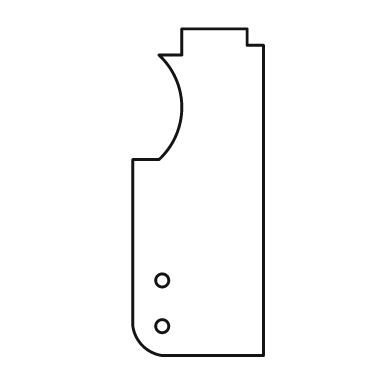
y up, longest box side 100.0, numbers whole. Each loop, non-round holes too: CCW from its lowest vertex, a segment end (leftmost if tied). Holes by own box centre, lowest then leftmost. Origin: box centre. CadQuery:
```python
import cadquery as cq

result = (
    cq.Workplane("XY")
    .moveTo(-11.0, -50.0)
    .lineTo(20.0, -50.0)
    .lineTo(20.0, 45.0)
    .lineTo(15.0, 45.0)
    .lineTo(15.0, 50.0)
    .lineTo(-5.0, 50.0)
    .lineTo(-5.0, 42.0)
    .lineTo(-12.0, 42.0)
    .threePointArc((-5.0, 26.0), (-12.0, 10.0))
    .lineTo(-20.0, 10.0)
    .lineTo(-20.0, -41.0)
    .threePointArc((-17.0, -47.0), (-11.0, -50.0))
    .close()
    .moveTo(-11.0, -41.0)
    .circle(2.0)
    .moveTo(-11.0, -27.0)
    .circle(2.0)
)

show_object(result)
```